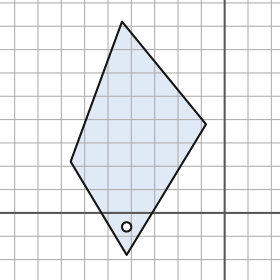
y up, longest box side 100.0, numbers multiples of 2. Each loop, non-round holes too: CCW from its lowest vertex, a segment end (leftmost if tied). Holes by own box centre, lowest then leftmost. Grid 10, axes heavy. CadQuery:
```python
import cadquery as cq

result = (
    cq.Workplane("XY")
    .moveTo(-42.0, -18.0)
    .lineTo(-8.0, 38.0)
    .lineTo(-44.0, 82.0)
    .lineTo(-66.0, 22.0)
    .close()
    .moveTo(-42.0, -6.0)
    .circle(2.0)
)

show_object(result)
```